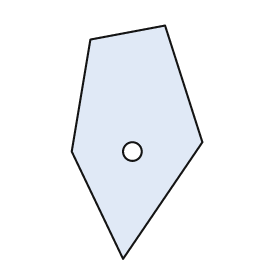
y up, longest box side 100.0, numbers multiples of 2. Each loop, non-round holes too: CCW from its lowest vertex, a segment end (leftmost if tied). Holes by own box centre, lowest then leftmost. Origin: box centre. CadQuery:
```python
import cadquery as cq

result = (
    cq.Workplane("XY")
    .moveTo(-6.0, -50.0)
    .lineTo(28.0, 0.0)
    .lineTo(12.0, 50.0)
    .lineTo(-20.0, 44.0)
    .lineTo(-28.0, -4.0)
    .close()
    .moveTo(-2.0, -4.0)
    .circle(4.0)
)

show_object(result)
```